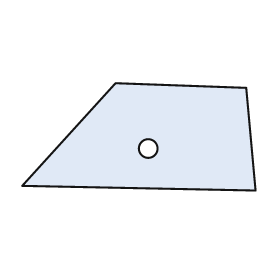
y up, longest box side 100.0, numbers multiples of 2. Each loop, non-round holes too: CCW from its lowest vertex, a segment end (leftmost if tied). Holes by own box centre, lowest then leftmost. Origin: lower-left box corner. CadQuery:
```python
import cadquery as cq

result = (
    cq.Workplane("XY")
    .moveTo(100.0, 0.0)
    .lineTo(96.0, 44.0)
    .lineTo(40.0, 46.0)
    .lineTo(0.0, 2.0)
    .close()
    .moveTo(54.0, 18.0)
    .circle(4.0)
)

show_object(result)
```